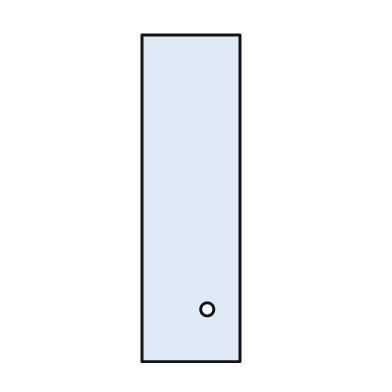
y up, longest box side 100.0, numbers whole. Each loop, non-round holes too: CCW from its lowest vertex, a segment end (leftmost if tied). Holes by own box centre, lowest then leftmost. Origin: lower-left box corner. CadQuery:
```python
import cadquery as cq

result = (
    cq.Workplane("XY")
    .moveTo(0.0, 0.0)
    .lineTo(30.0, 0.0)
    .lineTo(30.0, 100.0)
    .lineTo(0.0, 100.0)
    .close()
    .moveTo(20.0, 16.0)
    .circle(2.0)
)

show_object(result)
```